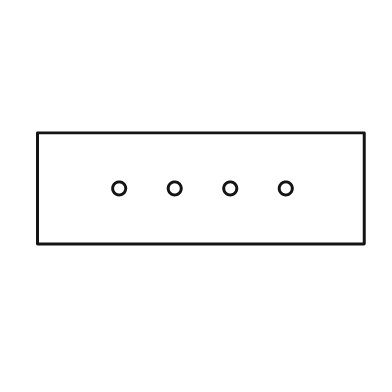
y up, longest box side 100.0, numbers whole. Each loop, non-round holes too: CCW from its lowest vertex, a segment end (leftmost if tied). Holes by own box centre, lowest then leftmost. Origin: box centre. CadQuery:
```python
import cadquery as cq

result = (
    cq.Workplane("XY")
    .moveTo(-50.0, -17.0)
    .lineTo(50.0, -17.0)
    .lineTo(50.0, 17.0)
    .lineTo(-50.0, 17.0)
    .close()
    .moveTo(-25.0, 0.0)
    .circle(2.0)
    .moveTo(-8.0, 0.0)
    .circle(2.0)
    .moveTo(9.0, 0.0)
    .circle(2.0)
    .moveTo(26.0, 0.0)
    .circle(2.0)
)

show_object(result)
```